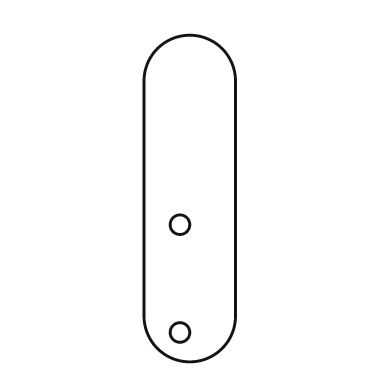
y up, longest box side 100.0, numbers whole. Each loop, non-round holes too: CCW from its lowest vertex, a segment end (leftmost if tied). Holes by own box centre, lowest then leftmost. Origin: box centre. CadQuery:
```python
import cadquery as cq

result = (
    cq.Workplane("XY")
    .moveTo(-14.0, -36.0)
    .threePointArc((0.0, -50.0), (14.0, -36.0))
    .lineTo(14.0, 36.0)
    .threePointArc((0.0, 50.0), (-14.0, 36.0))
    .close()
    .moveTo(-3.0, -41.0)
    .circle(3.0)
    .moveTo(-3.0, -8.0)
    .circle(3.0)
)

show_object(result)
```